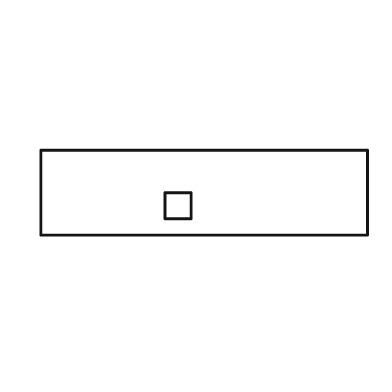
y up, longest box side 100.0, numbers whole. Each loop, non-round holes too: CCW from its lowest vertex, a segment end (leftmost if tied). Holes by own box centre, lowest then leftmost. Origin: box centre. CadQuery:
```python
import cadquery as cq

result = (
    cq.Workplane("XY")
    .moveTo(-50.0, -13.0)
    .lineTo(50.0, -13.0)
    .lineTo(50.0, 13.0)
    .lineTo(-50.0, 13.0)
    .close()
    .moveTo(-12.0, -8.0)
    .lineTo(-4.0, -8.0)
    .lineTo(-4.0, 0.0)
    .lineTo(-12.0, 0.0)
    .close()
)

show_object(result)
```